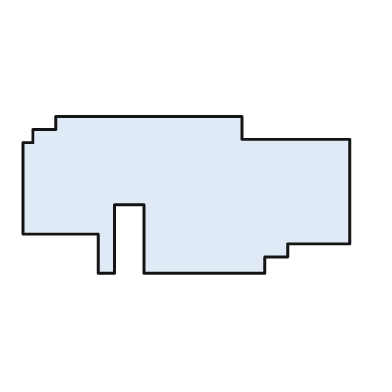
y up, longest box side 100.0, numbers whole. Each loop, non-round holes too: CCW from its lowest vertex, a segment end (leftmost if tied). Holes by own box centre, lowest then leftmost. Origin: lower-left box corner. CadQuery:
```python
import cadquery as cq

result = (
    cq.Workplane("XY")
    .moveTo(23.0, 0.0)
    .lineTo(28.0, 0.0)
    .lineTo(28.0, 21.0)
    .lineTo(37.0, 21.0)
    .lineTo(37.0, 0.0)
    .lineTo(74.0, 0.0)
    .lineTo(74.0, 5.0)
    .lineTo(81.0, 5.0)
    .lineTo(81.0, 9.0)
    .lineTo(100.0, 9.0)
    .lineTo(100.0, 41.0)
    .lineTo(67.0, 41.0)
    .lineTo(67.0, 48.0)
    .lineTo(10.0, 48.0)
    .lineTo(10.0, 44.0)
    .lineTo(3.0, 44.0)
    .lineTo(3.0, 40.0)
    .lineTo(0.0, 40.0)
    .lineTo(0.0, 12.0)
    .lineTo(23.0, 12.0)
    .close()
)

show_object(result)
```